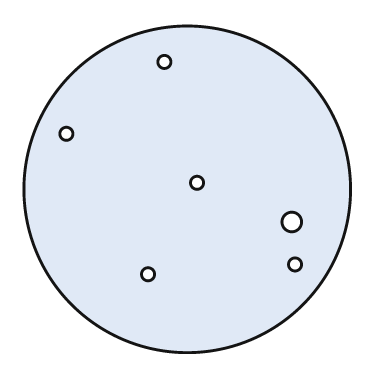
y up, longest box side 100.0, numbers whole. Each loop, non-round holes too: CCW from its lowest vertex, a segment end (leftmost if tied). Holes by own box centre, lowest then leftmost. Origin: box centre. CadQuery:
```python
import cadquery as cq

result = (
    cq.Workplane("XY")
    .moveTo(0.0, 0.0)
    .circle(50.0)
    .moveTo(-12.0, -26.0)
    .circle(2.0)
    .moveTo(33.0, -23.0)
    .circle(2.0)
    .moveTo(32.0, -10.0)
    .circle(3.0)
    .moveTo(3.0, 2.0)
    .circle(2.0)
    .moveTo(-37.0, 17.0)
    .circle(2.0)
    .moveTo(-7.0, 39.0)
    .circle(2.0)
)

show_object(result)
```